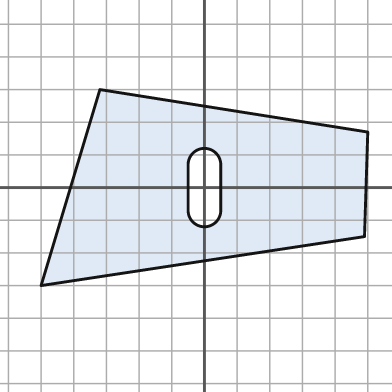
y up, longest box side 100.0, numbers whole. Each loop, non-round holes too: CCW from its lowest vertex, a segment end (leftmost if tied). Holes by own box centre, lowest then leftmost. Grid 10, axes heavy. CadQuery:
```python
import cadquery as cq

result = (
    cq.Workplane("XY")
    .moveTo(-50.0, -30.0)
    .lineTo(49.0, -15.0)
    .lineTo(50.0, 17.0)
    .lineTo(-32.0, 30.0)
    .close()
    .moveTo(-5.0, -7.0)
    .threePointArc((0.0, -12.0), (5.0, -7.0))
    .lineTo(5.0, 7.0)
    .threePointArc((0.0, 12.0), (-5.0, 7.0))
    .close()
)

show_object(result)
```